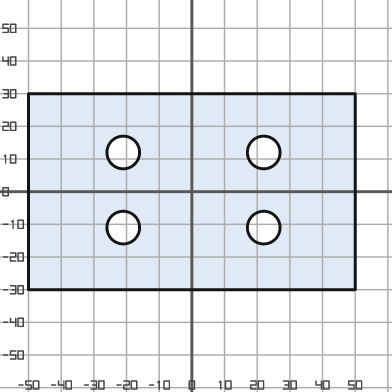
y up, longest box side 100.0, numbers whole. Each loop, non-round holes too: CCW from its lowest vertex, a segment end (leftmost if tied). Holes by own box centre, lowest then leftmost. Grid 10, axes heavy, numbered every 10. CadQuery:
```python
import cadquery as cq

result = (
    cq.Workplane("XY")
    .moveTo(-50.0, -30.0)
    .lineTo(50.0, -30.0)
    .lineTo(50.0, 30.0)
    .lineTo(-50.0, 30.0)
    .close()
    .moveTo(-21.0, -11.0)
    .circle(5.0)
    .moveTo(22.0, -11.0)
    .circle(5.0)
    .moveTo(-21.0, 12.0)
    .circle(5.0)
    .moveTo(22.0, 12.0)
    .circle(5.0)
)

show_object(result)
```